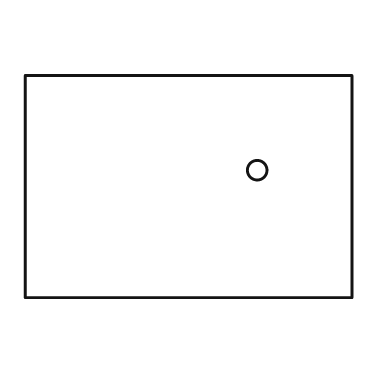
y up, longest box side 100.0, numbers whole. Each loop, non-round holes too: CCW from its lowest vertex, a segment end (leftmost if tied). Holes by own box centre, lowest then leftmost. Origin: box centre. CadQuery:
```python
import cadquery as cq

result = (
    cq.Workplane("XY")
    .moveTo(-50.0, -34.0)
    .lineTo(50.0, -34.0)
    .lineTo(50.0, 34.0)
    .lineTo(-50.0, 34.0)
    .close()
    .moveTo(21.0, 5.0)
    .circle(3.0)
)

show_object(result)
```